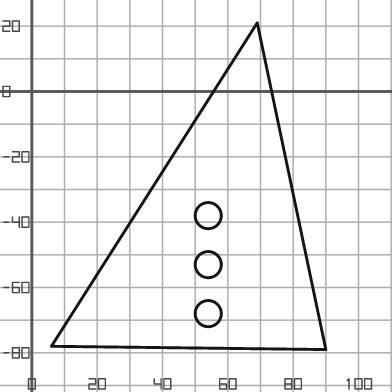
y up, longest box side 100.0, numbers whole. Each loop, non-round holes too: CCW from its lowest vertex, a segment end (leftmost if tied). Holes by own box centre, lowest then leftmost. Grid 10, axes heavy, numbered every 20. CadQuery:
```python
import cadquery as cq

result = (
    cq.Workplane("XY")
    .moveTo(90.0, -79.0)
    .lineTo(69.0, 21.0)
    .lineTo(6.0, -78.0)
    .close()
    .moveTo(54.0, -68.0)
    .circle(4.0)
    .moveTo(54.0, -53.0)
    .circle(4.0)
    .moveTo(54.0, -38.0)
    .circle(4.0)
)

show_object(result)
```